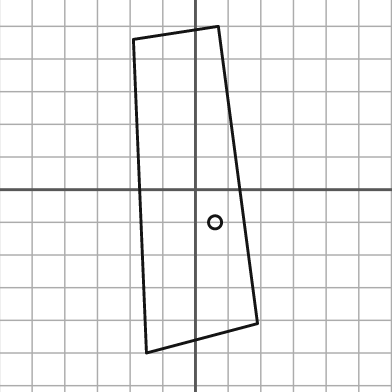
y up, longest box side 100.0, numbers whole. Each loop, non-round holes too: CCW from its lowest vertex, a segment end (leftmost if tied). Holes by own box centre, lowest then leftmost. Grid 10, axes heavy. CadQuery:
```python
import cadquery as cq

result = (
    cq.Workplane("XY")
    .moveTo(-15.0, -50.0)
    .lineTo(19.0, -41.0)
    .lineTo(7.0, 50.0)
    .lineTo(-19.0, 46.0)
    .close()
    .moveTo(6.0, -10.0)
    .circle(2.0)
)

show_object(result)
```